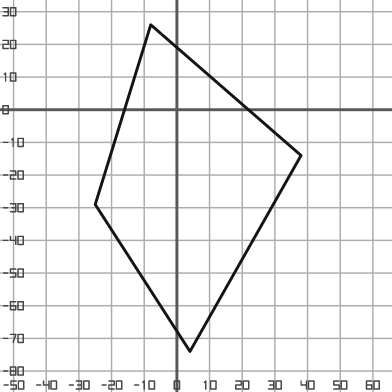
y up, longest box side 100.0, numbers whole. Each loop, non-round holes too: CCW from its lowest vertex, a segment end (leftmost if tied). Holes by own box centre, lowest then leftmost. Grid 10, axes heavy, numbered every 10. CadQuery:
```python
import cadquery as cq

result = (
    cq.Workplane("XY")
    .moveTo(4.0, -74.0)
    .lineTo(38.0, -14.0)
    .lineTo(-8.0, 26.0)
    .lineTo(-25.0, -29.0)
    .close()
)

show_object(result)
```